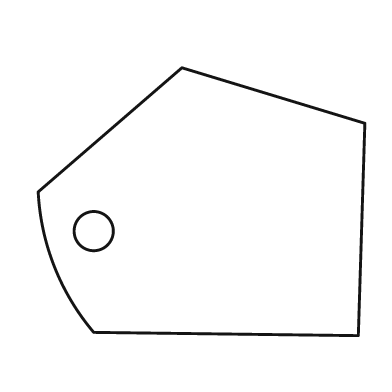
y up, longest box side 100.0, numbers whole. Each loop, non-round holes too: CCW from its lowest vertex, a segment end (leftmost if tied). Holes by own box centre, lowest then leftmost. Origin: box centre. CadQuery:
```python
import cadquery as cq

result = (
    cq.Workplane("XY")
    .moveTo(48.0, -41.0)
    .lineTo(50.0, 24.0)
    .lineTo(-6.0, 41.0)
    .lineTo(-50.0, 3.0)
    .threePointArc((-45.0, -20.0), (-33.0, -40.0))
    .close()
    .moveTo(-33.0, -9.0)
    .circle(6.0)
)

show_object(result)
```